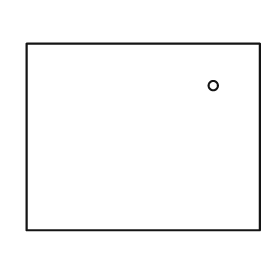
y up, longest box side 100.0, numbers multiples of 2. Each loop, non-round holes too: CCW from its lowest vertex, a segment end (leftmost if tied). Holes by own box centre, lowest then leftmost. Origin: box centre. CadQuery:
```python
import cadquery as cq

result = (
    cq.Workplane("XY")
    .moveTo(-50.0, -40.0)
    .lineTo(50.0, -40.0)
    .lineTo(50.0, 40.0)
    .lineTo(-50.0, 40.0)
    .close()
    .moveTo(30.0, 22.0)
    .circle(2.0)
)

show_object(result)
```